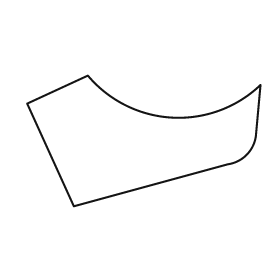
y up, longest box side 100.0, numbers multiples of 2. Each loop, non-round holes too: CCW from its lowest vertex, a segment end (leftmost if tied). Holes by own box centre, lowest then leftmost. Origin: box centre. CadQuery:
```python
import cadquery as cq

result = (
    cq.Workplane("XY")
    .moveTo(-30.0, -28.0)
    .lineTo(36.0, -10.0)
    .threePointArc((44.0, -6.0), (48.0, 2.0))
    .lineTo(50.0, 24.0)
    .threePointArc((12.0, 10.0), (-24.0, 28.0))
    .lineTo(-50.0, 16.0)
    .close()
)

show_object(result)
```